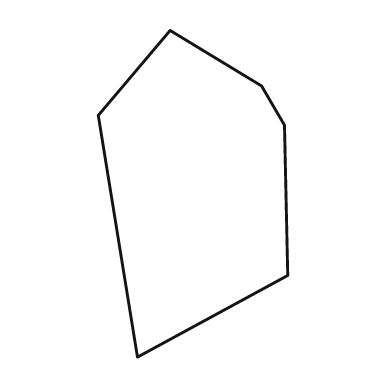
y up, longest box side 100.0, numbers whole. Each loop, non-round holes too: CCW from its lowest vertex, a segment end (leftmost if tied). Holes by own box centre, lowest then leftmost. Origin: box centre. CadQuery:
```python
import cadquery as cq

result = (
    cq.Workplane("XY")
    .moveTo(-17.0, -50.0)
    .lineTo(29.0, -25.0)
    .lineTo(28.0, 21.0)
    .lineTo(21.0, 33.0)
    .lineTo(-7.0, 50.0)
    .lineTo(-29.0, 24.0)
    .close()
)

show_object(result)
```